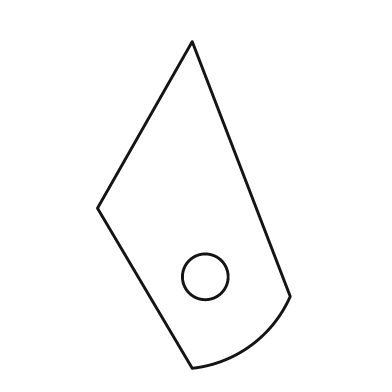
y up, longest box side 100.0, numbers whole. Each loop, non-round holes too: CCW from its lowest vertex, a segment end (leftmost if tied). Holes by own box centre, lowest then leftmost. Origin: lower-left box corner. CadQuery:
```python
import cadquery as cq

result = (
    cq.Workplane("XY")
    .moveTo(29.0, 0.0)
    .threePointArc((47.0, 7.0), (59.0, 22.0))
    .lineTo(29.0, 100.0)
    .lineTo(0.0, 49.0)
    .close()
    .moveTo(33.0, 28.0)
    .circle(7.0)
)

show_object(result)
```